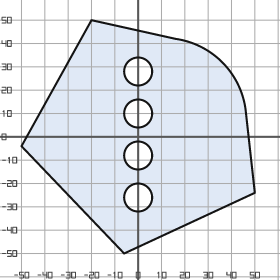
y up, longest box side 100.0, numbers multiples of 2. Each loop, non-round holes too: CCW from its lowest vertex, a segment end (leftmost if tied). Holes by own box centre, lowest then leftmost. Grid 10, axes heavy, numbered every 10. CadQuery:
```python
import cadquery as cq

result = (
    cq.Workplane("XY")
    .moveTo(-6.0, -50.0)
    .lineTo(50.0, -24.0)
    .lineTo(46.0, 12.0)
    .threePointArc((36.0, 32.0), (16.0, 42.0))
    .lineTo(-20.0, 50.0)
    .lineTo(-50.0, -4.0)
    .close()
    .moveTo(0.0, -26.0)
    .circle(6.0)
    .moveTo(0.0, -8.0)
    .circle(6.0)
    .moveTo(0.0, 10.0)
    .circle(6.0)
    .moveTo(0.0, 28.0)
    .circle(6.0)
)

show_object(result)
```